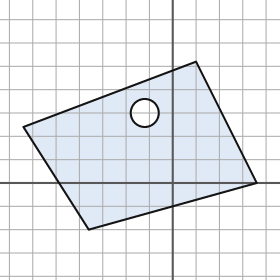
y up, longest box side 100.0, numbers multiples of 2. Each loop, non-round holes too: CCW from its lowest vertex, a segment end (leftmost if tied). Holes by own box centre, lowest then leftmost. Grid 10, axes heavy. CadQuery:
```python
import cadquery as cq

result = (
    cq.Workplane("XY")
    .moveTo(-36.0, -20.0)
    .lineTo(36.0, 0.0)
    .lineTo(10.0, 52.0)
    .lineTo(-64.0, 24.0)
    .close()
    .moveTo(-12.0, 30.0)
    .circle(6.0)
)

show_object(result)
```